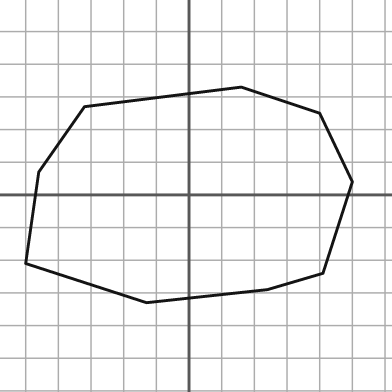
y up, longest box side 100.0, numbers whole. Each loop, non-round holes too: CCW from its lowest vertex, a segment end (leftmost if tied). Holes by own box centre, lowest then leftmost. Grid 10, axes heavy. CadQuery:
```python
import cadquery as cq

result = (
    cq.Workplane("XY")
    .moveTo(-13.0, -33.0)
    .lineTo(24.0, -29.0)
    .lineTo(41.0, -24.0)
    .lineTo(50.0, 4.0)
    .lineTo(40.0, 25.0)
    .lineTo(16.0, 33.0)
    .lineTo(-32.0, 27.0)
    .lineTo(-46.0, 7.0)
    .lineTo(-50.0, -21.0)
    .close()
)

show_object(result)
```